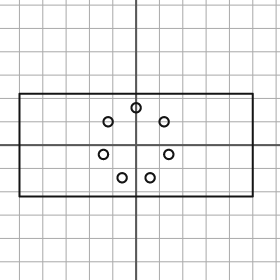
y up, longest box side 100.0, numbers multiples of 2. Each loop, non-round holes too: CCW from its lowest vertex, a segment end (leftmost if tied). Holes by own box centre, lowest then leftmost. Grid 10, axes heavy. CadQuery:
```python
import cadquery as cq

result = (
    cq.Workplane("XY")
    .moveTo(-50.0, -22.0)
    .lineTo(50.0, -22.0)
    .lineTo(50.0, 22.0)
    .lineTo(-50.0, 22.0)
    .close()
    .moveTo(-6.0, -14.0)
    .circle(2.0)
    .moveTo(6.0, -14.0)
    .circle(2.0)
    .moveTo(-14.0, -4.0)
    .circle(2.0)
    .moveTo(14.0, -4.0)
    .circle(2.0)
    .moveTo(-12.0, 10.0)
    .circle(2.0)
    .moveTo(12.0, 10.0)
    .circle(2.0)
    .moveTo(0.0, 16.0)
    .circle(2.0)
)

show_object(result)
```